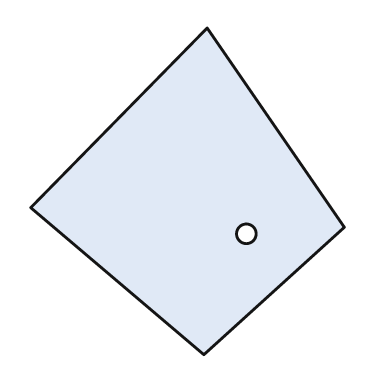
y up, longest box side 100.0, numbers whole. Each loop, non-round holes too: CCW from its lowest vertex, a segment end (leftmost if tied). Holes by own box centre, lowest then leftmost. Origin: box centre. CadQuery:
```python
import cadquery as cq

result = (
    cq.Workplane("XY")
    .moveTo(5.0, -50.0)
    .lineTo(48.0, -11.0)
    .lineTo(6.0, 50.0)
    .lineTo(-48.0, -5.0)
    .close()
    .moveTo(18.0, -13.0)
    .circle(3.0)
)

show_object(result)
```